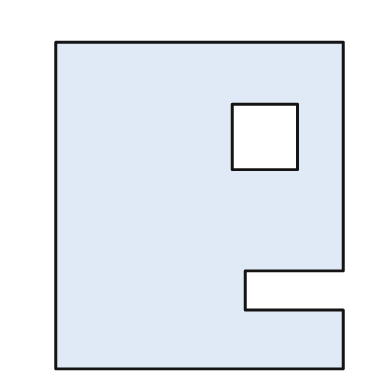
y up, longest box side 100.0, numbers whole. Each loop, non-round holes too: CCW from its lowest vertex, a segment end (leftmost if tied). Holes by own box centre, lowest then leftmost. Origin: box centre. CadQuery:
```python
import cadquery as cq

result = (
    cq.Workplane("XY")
    .moveTo(-44.0, -50.0)
    .lineTo(44.0, -50.0)
    .lineTo(44.0, -32.0)
    .lineTo(14.0, -32.0)
    .lineTo(14.0, -20.0)
    .lineTo(44.0, -20.0)
    .lineTo(44.0, 50.0)
    .lineTo(-44.0, 50.0)
    .close()
    .moveTo(10.0, 11.0)
    .lineTo(30.0, 11.0)
    .lineTo(30.0, 31.0)
    .lineTo(10.0, 31.0)
    .close()
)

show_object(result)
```